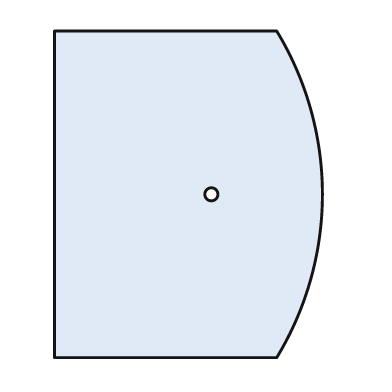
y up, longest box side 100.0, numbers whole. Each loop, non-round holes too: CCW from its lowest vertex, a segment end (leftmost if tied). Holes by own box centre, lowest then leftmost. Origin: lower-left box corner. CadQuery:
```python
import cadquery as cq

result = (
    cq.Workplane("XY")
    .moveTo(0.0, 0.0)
    .lineTo(68.0, 0.0)
    .threePointArc((82.0, 50.0), (68.0, 100.0))
    .lineTo(0.0, 100.0)
    .close()
    .moveTo(48.0, 50.0)
    .circle(2.0)
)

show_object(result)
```